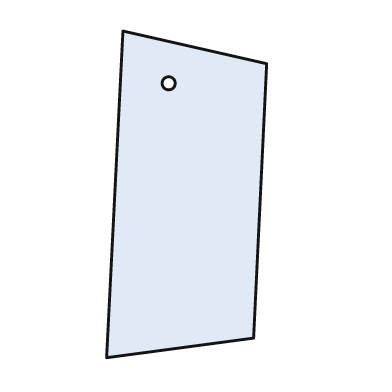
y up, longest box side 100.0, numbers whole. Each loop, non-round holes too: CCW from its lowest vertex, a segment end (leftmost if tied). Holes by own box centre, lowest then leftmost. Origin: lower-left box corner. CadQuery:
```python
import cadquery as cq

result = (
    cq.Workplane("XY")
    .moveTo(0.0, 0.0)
    .lineTo(45.0, 6.0)
    .lineTo(49.0, 90.0)
    .lineTo(5.0, 100.0)
    .close()
    .moveTo(19.0, 84.0)
    .circle(2.0)
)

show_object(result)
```